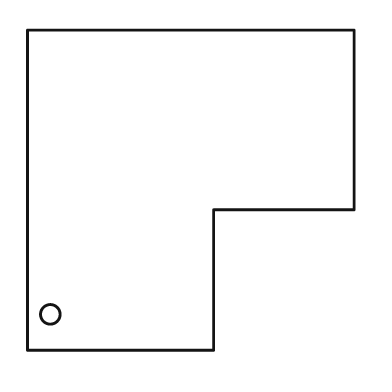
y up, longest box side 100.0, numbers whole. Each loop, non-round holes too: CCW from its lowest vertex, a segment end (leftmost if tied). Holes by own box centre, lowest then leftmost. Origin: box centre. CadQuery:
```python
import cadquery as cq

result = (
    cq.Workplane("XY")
    .moveTo(-50.0, -49.0)
    .lineTo(7.0, -49.0)
    .lineTo(7.0, -6.0)
    .lineTo(50.0, -6.0)
    .lineTo(50.0, 49.0)
    .lineTo(-50.0, 49.0)
    .close()
    .moveTo(-43.0, -38.0)
    .circle(3.0)
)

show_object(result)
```